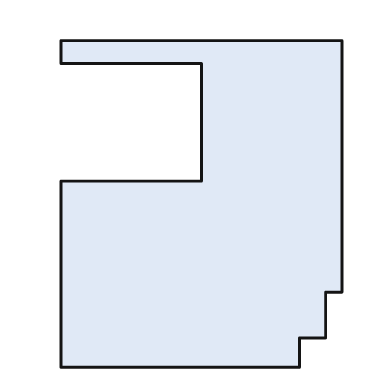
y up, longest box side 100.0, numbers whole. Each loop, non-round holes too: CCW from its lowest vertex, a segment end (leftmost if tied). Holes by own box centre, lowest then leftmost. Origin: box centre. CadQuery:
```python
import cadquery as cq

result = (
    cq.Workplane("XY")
    .moveTo(-43.0, -50.0)
    .lineTo(30.0, -50.0)
    .lineTo(30.0, -41.0)
    .lineTo(38.0, -41.0)
    .lineTo(38.0, -27.0)
    .lineTo(43.0, -27.0)
    .lineTo(43.0, 50.0)
    .lineTo(-43.0, 50.0)
    .lineTo(-43.0, 43.0)
    .lineTo(0.0, 43.0)
    .lineTo(0.0, 7.0)
    .lineTo(-43.0, 7.0)
    .close()
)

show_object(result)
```